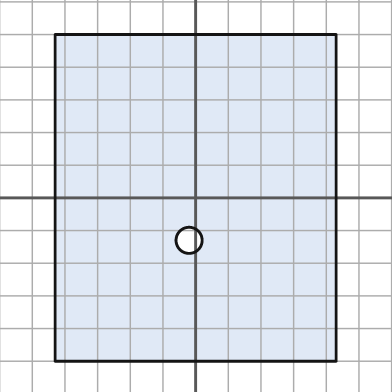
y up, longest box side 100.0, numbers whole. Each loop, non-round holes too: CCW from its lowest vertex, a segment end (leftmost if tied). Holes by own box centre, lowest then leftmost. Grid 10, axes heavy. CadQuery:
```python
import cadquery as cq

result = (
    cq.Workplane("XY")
    .moveTo(-43.0, -50.0)
    .lineTo(43.0, -50.0)
    .lineTo(43.0, 50.0)
    .lineTo(-43.0, 50.0)
    .close()
    .moveTo(-2.0, -13.0)
    .circle(4.0)
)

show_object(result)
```